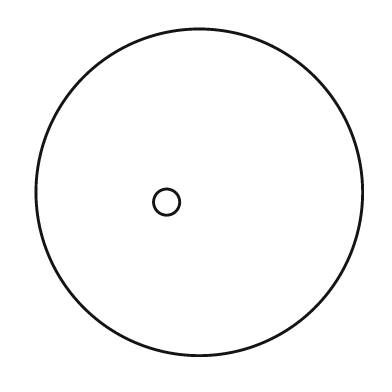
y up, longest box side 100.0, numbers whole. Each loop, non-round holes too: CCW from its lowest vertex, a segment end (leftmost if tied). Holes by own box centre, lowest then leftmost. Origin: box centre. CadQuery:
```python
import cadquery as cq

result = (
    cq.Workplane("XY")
    .moveTo(0.0, 0.0)
    .circle(50.0)
    .moveTo(-10.0, -3.0)
    .circle(4.0)
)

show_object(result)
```